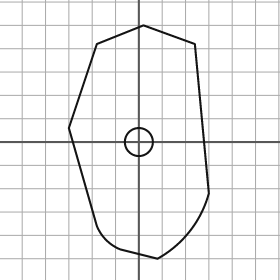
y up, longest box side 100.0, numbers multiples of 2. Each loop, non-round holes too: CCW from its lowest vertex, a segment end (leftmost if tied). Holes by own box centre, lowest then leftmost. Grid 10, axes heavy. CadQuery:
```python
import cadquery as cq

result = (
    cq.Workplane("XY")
    .moveTo(8.0, -50.0)
    .threePointArc((22.0, -38.0), (30.0, -22.0))
    .lineTo(24.0, 42.0)
    .lineTo(2.0, 50.0)
    .lineTo(-18.0, 42.0)
    .lineTo(-30.0, 6.0)
    .lineTo(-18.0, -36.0)
    .threePointArc((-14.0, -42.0), (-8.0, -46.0))
    .close()
    .moveTo(0.0, 0.0)
    .circle(6.0)
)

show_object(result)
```